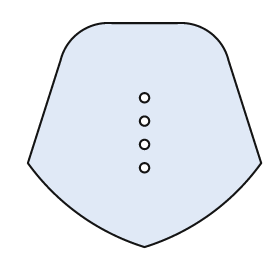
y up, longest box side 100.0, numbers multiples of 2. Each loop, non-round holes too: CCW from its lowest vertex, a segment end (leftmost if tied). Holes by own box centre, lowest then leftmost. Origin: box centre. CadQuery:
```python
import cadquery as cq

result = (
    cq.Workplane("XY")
    .moveTo(0.0, -48.0)
    .threePointArc((28.0, -34.0), (50.0, -12.0))
    .lineTo(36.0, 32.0)
    .threePointArc((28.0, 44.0), (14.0, 48.0))
    .lineTo(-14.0, 48.0)
    .threePointArc((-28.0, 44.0), (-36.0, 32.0))
    .lineTo(-50.0, -12.0)
    .threePointArc((-28.0, -34.0), (0.0, -48.0))
    .close()
    .moveTo(0.0, -14.0)
    .circle(2.0)
    .moveTo(0.0, -4.0)
    .circle(2.0)
    .moveTo(0.0, 6.0)
    .circle(2.0)
    .moveTo(0.0, 16.0)
    .circle(2.0)
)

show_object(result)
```